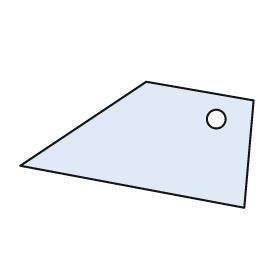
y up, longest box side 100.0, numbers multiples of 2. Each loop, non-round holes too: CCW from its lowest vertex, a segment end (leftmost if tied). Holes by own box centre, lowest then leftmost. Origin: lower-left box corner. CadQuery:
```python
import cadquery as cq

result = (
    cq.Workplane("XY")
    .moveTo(96.0, 0.0)
    .lineTo(100.0, 46.0)
    .lineTo(54.0, 54.0)
    .lineTo(0.0, 18.0)
    .close()
    .moveTo(84.0, 38.0)
    .circle(4.0)
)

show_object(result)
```